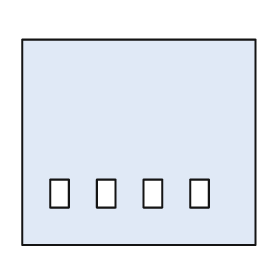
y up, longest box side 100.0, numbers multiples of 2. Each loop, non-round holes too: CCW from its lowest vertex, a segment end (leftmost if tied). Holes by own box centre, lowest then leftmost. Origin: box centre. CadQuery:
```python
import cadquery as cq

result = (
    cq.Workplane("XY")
    .moveTo(-50.0, -44.0)
    .lineTo(50.0, -44.0)
    .lineTo(50.0, 44.0)
    .lineTo(-50.0, 44.0)
    .close()
    .moveTo(-38.0, -28.0)
    .lineTo(-30.0, -28.0)
    .lineTo(-30.0, -16.0)
    .lineTo(-38.0, -16.0)
    .close()
    .moveTo(-18.0, -28.0)
    .lineTo(-10.0, -28.0)
    .lineTo(-10.0, -16.0)
    .lineTo(-18.0, -16.0)
    .close()
    .moveTo(2.0, -28.0)
    .lineTo(10.0, -28.0)
    .lineTo(10.0, -16.0)
    .lineTo(2.0, -16.0)
    .close()
    .moveTo(22.0, -28.0)
    .lineTo(30.0, -28.0)
    .lineTo(30.0, -16.0)
    .lineTo(22.0, -16.0)
    .close()
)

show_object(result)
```